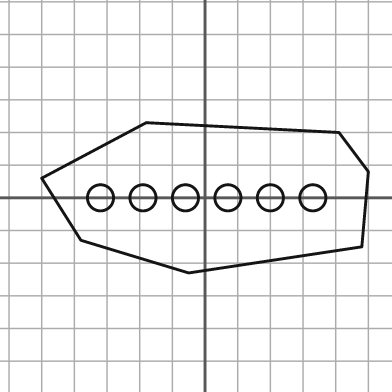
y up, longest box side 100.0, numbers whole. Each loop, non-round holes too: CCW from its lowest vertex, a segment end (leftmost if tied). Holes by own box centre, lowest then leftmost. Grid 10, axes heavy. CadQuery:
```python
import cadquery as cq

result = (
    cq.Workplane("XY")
    .moveTo(-5.0, -23.0)
    .lineTo(48.0, -15.0)
    .lineTo(50.0, 8.0)
    .lineTo(41.0, 20.0)
    .lineTo(-18.0, 23.0)
    .lineTo(-50.0, 6.0)
    .lineTo(-38.0, -13.0)
    .close()
    .moveTo(-32.0, 0.0)
    .circle(4.0)
    .moveTo(-19.0, 0.0)
    .circle(4.0)
    .moveTo(-6.0, 0.0)
    .circle(4.0)
    .moveTo(7.0, 0.0)
    .circle(4.0)
    .moveTo(20.0, 0.0)
    .circle(4.0)
    .moveTo(33.0, 0.0)
    .circle(4.0)
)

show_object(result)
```